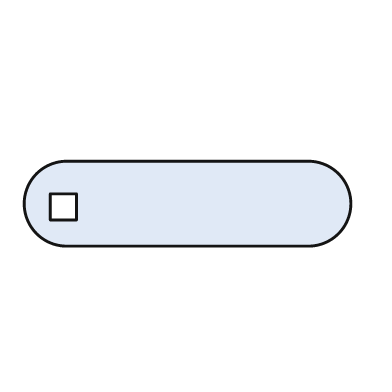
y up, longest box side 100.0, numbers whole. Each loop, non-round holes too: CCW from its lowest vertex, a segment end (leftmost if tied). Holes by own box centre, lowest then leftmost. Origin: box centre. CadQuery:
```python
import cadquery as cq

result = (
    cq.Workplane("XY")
    .moveTo(-37.0, -13.0)
    .lineTo(37.0, -13.0)
    .threePointArc((50.0, 0.0), (37.0, 13.0))
    .lineTo(-37.0, 13.0)
    .threePointArc((-50.0, 0.0), (-37.0, -13.0))
    .close()
    .moveTo(-42.0, -5.0)
    .lineTo(-34.0, -5.0)
    .lineTo(-34.0, 3.0)
    .lineTo(-42.0, 3.0)
    .close()
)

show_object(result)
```